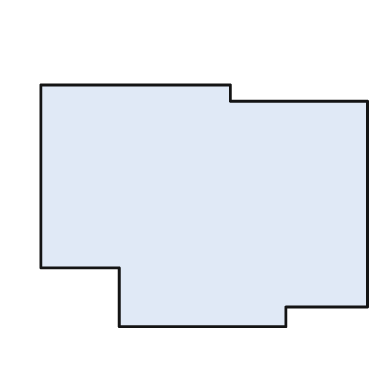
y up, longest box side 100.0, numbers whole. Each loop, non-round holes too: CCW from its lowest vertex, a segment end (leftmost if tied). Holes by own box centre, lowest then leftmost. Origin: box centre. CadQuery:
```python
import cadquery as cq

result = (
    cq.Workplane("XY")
    .moveTo(-26.0, -37.0)
    .lineTo(25.0, -37.0)
    .lineTo(25.0, -31.0)
    .lineTo(50.0, -31.0)
    .lineTo(50.0, 32.0)
    .lineTo(8.0, 32.0)
    .lineTo(8.0, 37.0)
    .lineTo(-50.0, 37.0)
    .lineTo(-50.0, -19.0)
    .lineTo(-26.0, -19.0)
    .close()
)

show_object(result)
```